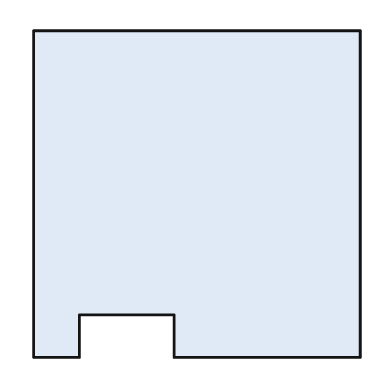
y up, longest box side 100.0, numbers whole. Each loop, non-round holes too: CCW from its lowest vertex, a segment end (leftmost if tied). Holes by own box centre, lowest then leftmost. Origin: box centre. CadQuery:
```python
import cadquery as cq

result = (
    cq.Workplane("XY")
    .moveTo(-50.0, -50.0)
    .lineTo(-36.0, -50.0)
    .lineTo(-36.0, -37.0)
    .lineTo(-7.0, -37.0)
    .lineTo(-7.0, -50.0)
    .lineTo(50.0, -50.0)
    .lineTo(50.0, 50.0)
    .lineTo(-50.0, 50.0)
    .close()
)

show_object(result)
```